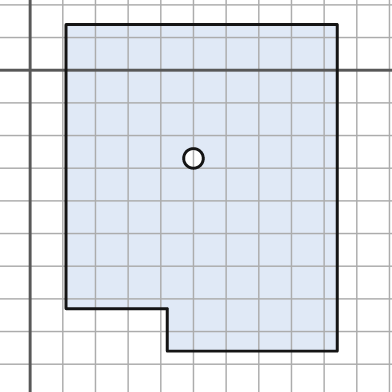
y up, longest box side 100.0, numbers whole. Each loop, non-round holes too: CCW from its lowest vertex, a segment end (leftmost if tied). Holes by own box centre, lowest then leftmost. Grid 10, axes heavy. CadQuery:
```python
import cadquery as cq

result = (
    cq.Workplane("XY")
    .moveTo(42.0, -86.0)
    .lineTo(94.0, -86.0)
    .lineTo(94.0, 14.0)
    .lineTo(11.0, 14.0)
    .lineTo(11.0, -73.0)
    .lineTo(42.0, -73.0)
    .close()
    .moveTo(50.0, -27.0)
    .circle(3.0)
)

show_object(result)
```